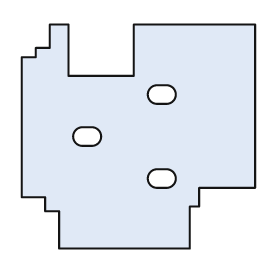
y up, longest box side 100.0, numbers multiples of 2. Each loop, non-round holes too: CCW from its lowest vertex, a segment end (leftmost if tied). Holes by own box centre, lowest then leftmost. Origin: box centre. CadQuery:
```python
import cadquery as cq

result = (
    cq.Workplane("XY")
    .moveTo(-34.0, -48.0)
    .lineTo(22.0, -48.0)
    .lineTo(22.0, -30.0)
    .lineTo(26.0, -30.0)
    .lineTo(26.0, -22.0)
    .lineTo(50.0, -22.0)
    .lineTo(50.0, 48.0)
    .lineTo(-2.0, 48.0)
    .lineTo(-2.0, 26.0)
    .lineTo(-30.0, 26.0)
    .lineTo(-30.0, 48.0)
    .lineTo(-38.0, 48.0)
    .lineTo(-38.0, 38.0)
    .lineTo(-44.0, 38.0)
    .lineTo(-44.0, 34.0)
    .lineTo(-50.0, 34.0)
    .lineTo(-50.0, -26.0)
    .lineTo(-40.0, -26.0)
    .lineTo(-40.0, -32.0)
    .lineTo(-34.0, -32.0)
    .close()
    .moveTo(8.0, -22.0)
    .lineTo(12.0, -22.0)
    .threePointArc((16.0, -18.0), (12.0, -14.0))
    .lineTo(8.0, -14.0)
    .threePointArc((4.0, -18.0), (8.0, -22.0))
    .close()
    .moveTo(-24.0, -4.0)
    .lineTo(-20.0, -4.0)
    .threePointArc((-16.0, 0.0), (-20.0, 4.0))
    .lineTo(-24.0, 4.0)
    .threePointArc((-28.0, 0.0), (-24.0, -4.0))
    .close()
    .moveTo(8.0, 14.0)
    .lineTo(12.0, 14.0)
    .threePointArc((16.0, 18.0), (12.0, 22.0))
    .lineTo(8.0, 22.0)
    .threePointArc((4.0, 18.0), (8.0, 14.0))
    .close()
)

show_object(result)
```